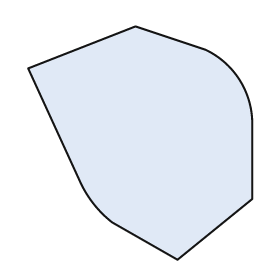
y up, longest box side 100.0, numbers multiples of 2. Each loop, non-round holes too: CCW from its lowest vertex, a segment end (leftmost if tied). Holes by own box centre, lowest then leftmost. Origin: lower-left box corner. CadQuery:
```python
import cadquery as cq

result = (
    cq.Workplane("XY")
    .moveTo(64.0, 0.0)
    .lineTo(96.0, 26.0)
    .lineTo(96.0, 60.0)
    .threePointArc((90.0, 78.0), (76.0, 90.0))
    .lineTo(46.0, 100.0)
    .lineTo(0.0, 82.0)
    .lineTo(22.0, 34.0)
    .threePointArc((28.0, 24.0), (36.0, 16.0))
    .close()
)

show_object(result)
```